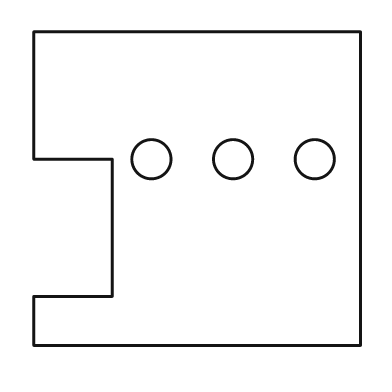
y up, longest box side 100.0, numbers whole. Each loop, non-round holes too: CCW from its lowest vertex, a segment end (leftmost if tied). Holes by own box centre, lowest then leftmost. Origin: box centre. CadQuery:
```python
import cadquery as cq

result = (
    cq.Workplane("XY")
    .moveTo(-50.0, -48.0)
    .lineTo(50.0, -48.0)
    .lineTo(50.0, 48.0)
    .lineTo(-50.0, 48.0)
    .lineTo(-50.0, 9.0)
    .lineTo(-26.0, 9.0)
    .lineTo(-26.0, -33.0)
    .lineTo(-50.0, -33.0)
    .close()
    .moveTo(-14.0, 9.0)
    .circle(6.0)
    .moveTo(11.0, 9.0)
    .circle(6.0)
    .moveTo(36.0, 9.0)
    .circle(6.0)
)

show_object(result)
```